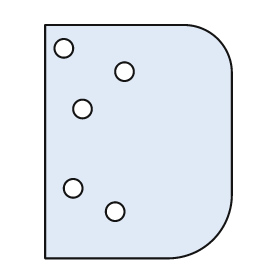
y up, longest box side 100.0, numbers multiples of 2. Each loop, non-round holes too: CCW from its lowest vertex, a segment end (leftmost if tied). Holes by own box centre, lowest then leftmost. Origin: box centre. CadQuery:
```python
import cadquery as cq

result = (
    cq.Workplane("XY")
    .moveTo(-40.0, -50.0)
    .lineTo(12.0, -50.0)
    .threePointArc((32.0, -42.0), (40.0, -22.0))
    .lineTo(40.0, 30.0)
    .threePointArc((34.0, 44.0), (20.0, 50.0))
    .lineTo(-40.0, 50.0)
    .close()
    .moveTo(-10.0, -30.0)
    .circle(4.0)
    .moveTo(-28.0, -20.0)
    .circle(4.0)
    .moveTo(-24.0, 14.0)
    .circle(4.0)
    .moveTo(-6.0, 30.0)
    .circle(4.0)
    .moveTo(-32.0, 40.0)
    .circle(4.0)
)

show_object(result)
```